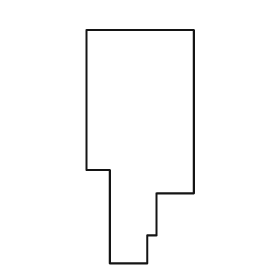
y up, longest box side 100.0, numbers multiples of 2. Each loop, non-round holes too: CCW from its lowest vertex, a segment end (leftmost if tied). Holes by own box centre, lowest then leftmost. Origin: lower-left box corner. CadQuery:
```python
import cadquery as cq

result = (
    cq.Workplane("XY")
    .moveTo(10.0, 0.0)
    .lineTo(26.0, 0.0)
    .lineTo(26.0, 12.0)
    .lineTo(30.0, 12.0)
    .lineTo(30.0, 30.0)
    .lineTo(46.0, 30.0)
    .lineTo(46.0, 100.0)
    .lineTo(0.0, 100.0)
    .lineTo(0.0, 40.0)
    .lineTo(10.0, 40.0)
    .close()
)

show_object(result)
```